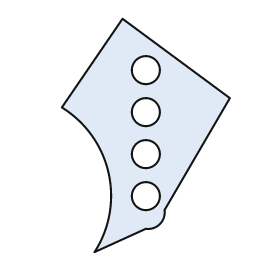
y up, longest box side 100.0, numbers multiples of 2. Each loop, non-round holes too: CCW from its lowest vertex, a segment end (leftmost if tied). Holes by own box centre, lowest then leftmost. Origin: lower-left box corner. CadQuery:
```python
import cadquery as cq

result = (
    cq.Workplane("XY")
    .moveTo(14.0, 0.0)
    .lineTo(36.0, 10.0)
    .threePointArc((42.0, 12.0), (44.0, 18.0))
    .lineTo(72.0, 66.0)
    .lineTo(26.0, 100.0)
    .lineTo(0.0, 62.0)
    .threePointArc((20.0, 34.0), (14.0, 0.0))
    .close()
    .moveTo(36.0, 24.0)
    .circle(6.0)
    .moveTo(36.0, 42.0)
    .circle(6.0)
    .moveTo(36.0, 60.0)
    .circle(6.0)
    .moveTo(36.0, 78.0)
    .circle(6.0)
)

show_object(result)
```